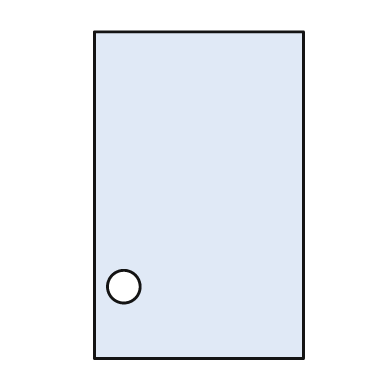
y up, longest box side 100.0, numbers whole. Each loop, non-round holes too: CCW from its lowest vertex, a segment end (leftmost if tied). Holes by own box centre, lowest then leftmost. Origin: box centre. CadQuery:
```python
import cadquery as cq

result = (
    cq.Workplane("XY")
    .moveTo(-32.0, -50.0)
    .lineTo(32.0, -50.0)
    .lineTo(32.0, 50.0)
    .lineTo(-32.0, 50.0)
    .close()
    .moveTo(-23.0, -28.0)
    .circle(5.0)
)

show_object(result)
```